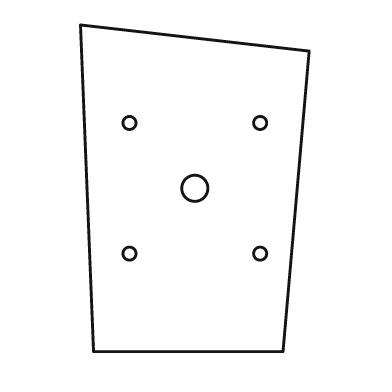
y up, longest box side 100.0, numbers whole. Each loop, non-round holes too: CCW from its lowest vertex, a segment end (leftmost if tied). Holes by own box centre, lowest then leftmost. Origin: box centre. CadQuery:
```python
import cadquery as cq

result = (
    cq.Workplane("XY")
    .moveTo(-31.0, -50.0)
    .lineTo(27.0, -50.0)
    .lineTo(35.0, 42.0)
    .lineTo(-35.0, 50.0)
    .close()
    .moveTo(-20.0, -20.0)
    .circle(2.0)
    .moveTo(20.0, -20.0)
    .circle(2.0)
    .moveTo(0.0, 0.0)
    .circle(4.0)
    .moveTo(-20.0, 20.0)
    .circle(2.0)
    .moveTo(20.0, 20.0)
    .circle(2.0)
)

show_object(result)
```